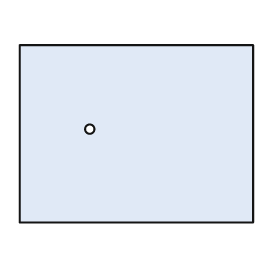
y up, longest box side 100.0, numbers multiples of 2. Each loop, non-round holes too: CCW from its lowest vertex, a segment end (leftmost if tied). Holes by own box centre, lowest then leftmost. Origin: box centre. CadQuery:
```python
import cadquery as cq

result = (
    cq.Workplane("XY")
    .moveTo(-50.0, -38.0)
    .lineTo(50.0, -38.0)
    .lineTo(50.0, 38.0)
    .lineTo(-50.0, 38.0)
    .close()
    .moveTo(-20.0, 2.0)
    .circle(2.0)
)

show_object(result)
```